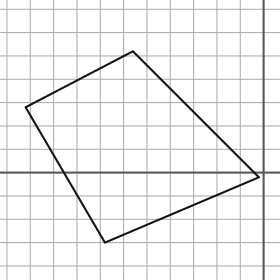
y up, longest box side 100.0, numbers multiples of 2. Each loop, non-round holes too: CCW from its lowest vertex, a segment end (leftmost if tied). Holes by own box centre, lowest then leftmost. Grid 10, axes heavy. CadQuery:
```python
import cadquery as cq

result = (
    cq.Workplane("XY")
    .moveTo(-68.0, -30.0)
    .lineTo(-2.0, -2.0)
    .lineTo(-56.0, 52.0)
    .lineTo(-102.0, 28.0)
    .close()
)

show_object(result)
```